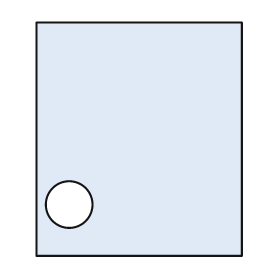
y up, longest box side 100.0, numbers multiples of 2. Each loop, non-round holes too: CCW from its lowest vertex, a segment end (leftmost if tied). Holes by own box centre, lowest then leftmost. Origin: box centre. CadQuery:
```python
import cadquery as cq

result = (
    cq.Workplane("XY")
    .moveTo(-44.0, -50.0)
    .lineTo(44.0, -50.0)
    .lineTo(44.0, 50.0)
    .lineTo(-44.0, 50.0)
    .close()
    .moveTo(-30.0, -28.0)
    .circle(10.0)
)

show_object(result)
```